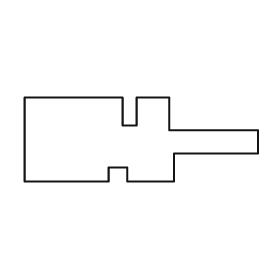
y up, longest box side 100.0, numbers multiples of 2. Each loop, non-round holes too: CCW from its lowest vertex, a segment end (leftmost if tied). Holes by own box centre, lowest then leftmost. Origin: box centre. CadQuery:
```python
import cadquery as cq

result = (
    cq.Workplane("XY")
    .moveTo(-50.0, -18.0)
    .lineTo(-14.0, -18.0)
    .lineTo(-14.0, -12.0)
    .lineTo(-6.0, -12.0)
    .lineTo(-6.0, -18.0)
    .lineTo(14.0, -18.0)
    .lineTo(14.0, -6.0)
    .lineTo(50.0, -6.0)
    .lineTo(50.0, 4.0)
    .lineTo(12.0, 4.0)
    .lineTo(12.0, 18.0)
    .lineTo(-2.0, 18.0)
    .lineTo(-2.0, 6.0)
    .lineTo(-8.0, 6.0)
    .lineTo(-8.0, 18.0)
    .lineTo(-50.0, 18.0)
    .close()
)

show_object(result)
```